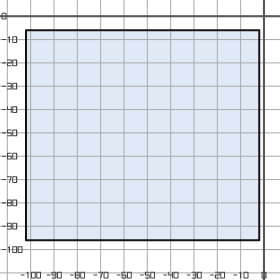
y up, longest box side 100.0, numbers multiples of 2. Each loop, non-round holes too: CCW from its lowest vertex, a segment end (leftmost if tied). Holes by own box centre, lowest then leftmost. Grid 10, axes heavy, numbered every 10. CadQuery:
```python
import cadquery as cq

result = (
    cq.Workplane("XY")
    .moveTo(-102.0, -96.0)
    .lineTo(-2.0, -96.0)
    .lineTo(-2.0, -6.0)
    .lineTo(-102.0, -6.0)
    .close()
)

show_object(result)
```